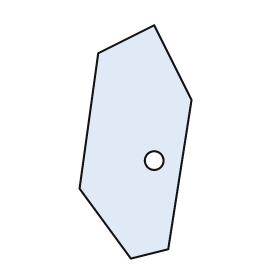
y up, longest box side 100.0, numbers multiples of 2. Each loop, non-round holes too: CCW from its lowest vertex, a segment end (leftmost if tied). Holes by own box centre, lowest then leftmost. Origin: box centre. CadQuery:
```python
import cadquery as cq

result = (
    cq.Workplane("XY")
    .moveTo(-2.0, -50.0)
    .lineTo(14.0, -46.0)
    .lineTo(24.0, 18.0)
    .lineTo(8.0, 50.0)
    .lineTo(-16.0, 38.0)
    .lineTo(-24.0, -20.0)
    .close()
    .moveTo(8.0, -8.0)
    .circle(4.0)
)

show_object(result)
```